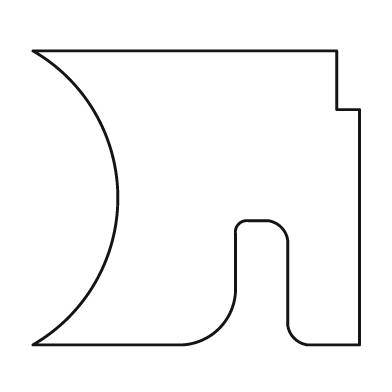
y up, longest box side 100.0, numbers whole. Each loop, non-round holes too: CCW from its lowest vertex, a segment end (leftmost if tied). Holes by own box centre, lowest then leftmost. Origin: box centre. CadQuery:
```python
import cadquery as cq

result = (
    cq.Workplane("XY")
    .moveTo(-50.0, -45.0)
    .lineTo(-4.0, -45.0)
    .threePointArc((7.0, -40.0), (12.0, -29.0))
    .lineTo(12.0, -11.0)
    .threePointArc((13.0, -8.0), (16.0, -7.0))
    .lineTo(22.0, -7.0)
    .threePointArc((26.0, -9.0), (28.0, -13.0))
    .lineTo(28.0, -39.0)
    .threePointArc((30.0, -43.0), (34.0, -45.0))
    .lineTo(50.0, -45.0)
    .lineTo(50.0, 27.0)
    .lineTo(43.0, 27.0)
    .lineTo(43.0, 45.0)
    .lineTo(-50.0, 45.0)
    .threePointArc((-24.0, 0.0), (-50.0, -45.0))
    .close()
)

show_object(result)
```